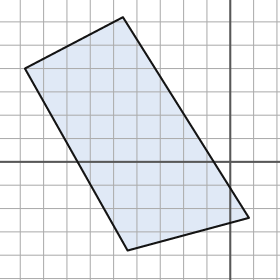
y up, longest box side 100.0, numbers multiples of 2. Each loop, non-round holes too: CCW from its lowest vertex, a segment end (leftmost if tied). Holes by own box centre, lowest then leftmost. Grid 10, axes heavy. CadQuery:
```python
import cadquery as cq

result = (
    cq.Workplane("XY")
    .moveTo(-44.0, -38.0)
    .lineTo(8.0, -24.0)
    .lineTo(-46.0, 62.0)
    .lineTo(-88.0, 40.0)
    .close()
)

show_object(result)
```